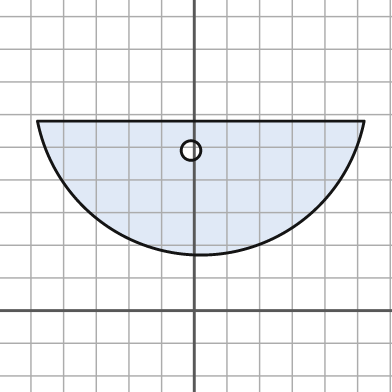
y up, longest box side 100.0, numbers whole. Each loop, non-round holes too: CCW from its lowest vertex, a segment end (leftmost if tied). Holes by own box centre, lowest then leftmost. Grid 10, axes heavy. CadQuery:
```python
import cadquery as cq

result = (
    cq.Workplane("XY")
    .moveTo(-48.0, 58.0)
    .threePointArc((2.0, 17.0), (52.0, 58.0))
    .close()
    .moveTo(-1.0, 49.0)
    .circle(3.0)
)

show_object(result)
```